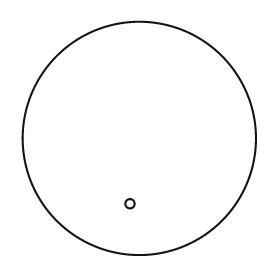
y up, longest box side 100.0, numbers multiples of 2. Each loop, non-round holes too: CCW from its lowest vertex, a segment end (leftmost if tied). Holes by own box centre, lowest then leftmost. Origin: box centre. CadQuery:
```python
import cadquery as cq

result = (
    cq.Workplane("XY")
    .moveTo(0.0, 0.0)
    .circle(50.0)
    .moveTo(-4.0, -28.0)
    .circle(2.0)
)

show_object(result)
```